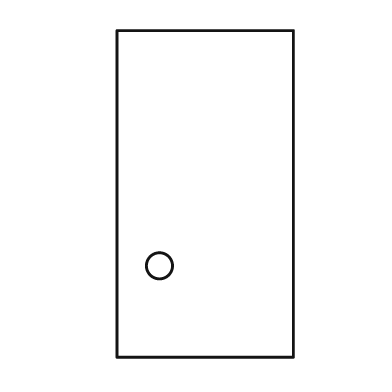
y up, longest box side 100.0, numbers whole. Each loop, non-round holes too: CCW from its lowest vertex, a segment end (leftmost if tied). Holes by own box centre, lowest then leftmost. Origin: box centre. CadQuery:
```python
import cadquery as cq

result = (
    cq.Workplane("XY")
    .moveTo(-27.0, -50.0)
    .lineTo(27.0, -50.0)
    .lineTo(27.0, 50.0)
    .lineTo(-27.0, 50.0)
    .close()
    .moveTo(-14.0, -22.0)
    .circle(4.0)
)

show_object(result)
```